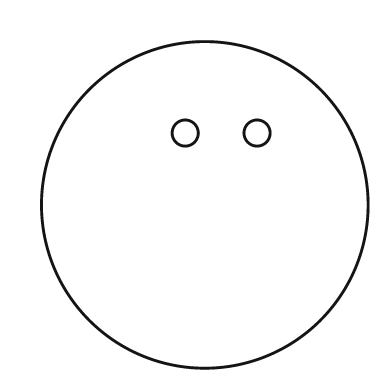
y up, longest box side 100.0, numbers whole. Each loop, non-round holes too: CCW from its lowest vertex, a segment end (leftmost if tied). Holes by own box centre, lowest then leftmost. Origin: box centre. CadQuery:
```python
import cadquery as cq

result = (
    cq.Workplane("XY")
    .moveTo(0.0, 0.0)
    .circle(50.0)
    .moveTo(-6.0, 22.0)
    .circle(4.0)
    .moveTo(16.0, 22.0)
    .circle(4.0)
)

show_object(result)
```